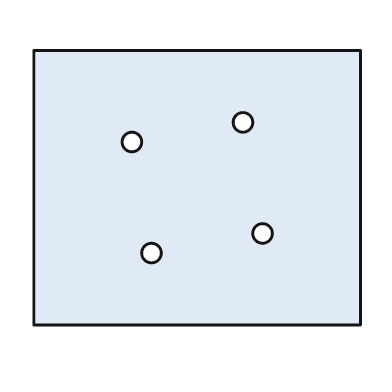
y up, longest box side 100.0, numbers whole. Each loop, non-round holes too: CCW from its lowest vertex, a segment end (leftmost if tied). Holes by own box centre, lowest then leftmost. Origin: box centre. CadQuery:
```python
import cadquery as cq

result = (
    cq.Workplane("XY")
    .moveTo(-50.0, -42.0)
    .lineTo(50.0, -42.0)
    .lineTo(50.0, 42.0)
    .lineTo(-50.0, 42.0)
    .close()
    .moveTo(-14.0, -20.0)
    .circle(3.0)
    .moveTo(20.0, -14.0)
    .circle(3.0)
    .moveTo(-20.0, 14.0)
    .circle(3.0)
    .moveTo(14.0, 20.0)
    .circle(3.0)
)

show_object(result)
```